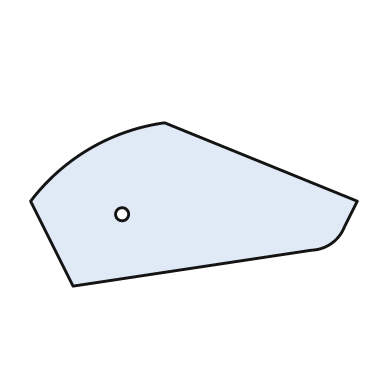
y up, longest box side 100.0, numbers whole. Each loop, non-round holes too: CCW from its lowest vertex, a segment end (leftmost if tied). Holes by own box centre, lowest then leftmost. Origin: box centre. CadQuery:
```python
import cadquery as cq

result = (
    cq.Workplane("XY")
    .moveTo(-37.0, -25.0)
    .lineTo(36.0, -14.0)
    .threePointArc((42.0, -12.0), (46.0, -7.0))
    .lineTo(50.0, 1.0)
    .lineTo(-9.0, 25.0)
    .threePointArc((-32.0, 17.0), (-50.0, 1.0))
    .close()
    .moveTo(-22.0, -3.0)
    .circle(2.0)
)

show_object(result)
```